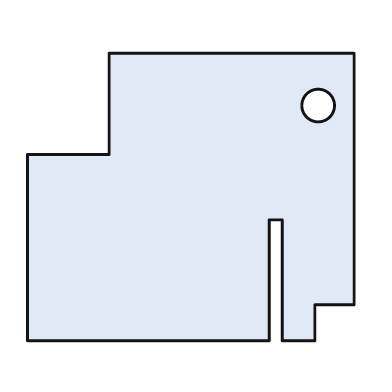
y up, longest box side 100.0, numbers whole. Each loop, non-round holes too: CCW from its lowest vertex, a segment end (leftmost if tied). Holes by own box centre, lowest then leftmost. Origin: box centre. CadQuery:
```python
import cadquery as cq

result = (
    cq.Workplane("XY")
    .moveTo(-50.0, -44.0)
    .lineTo(24.0, -44.0)
    .lineTo(24.0, -7.0)
    .lineTo(28.0, -7.0)
    .lineTo(28.0, -44.0)
    .lineTo(38.0, -44.0)
    .lineTo(38.0, -33.0)
    .lineTo(50.0, -33.0)
    .lineTo(50.0, 44.0)
    .lineTo(-25.0, 44.0)
    .lineTo(-25.0, 13.0)
    .lineTo(-50.0, 13.0)
    .close()
    .moveTo(39.0, 28.0)
    .circle(5.0)
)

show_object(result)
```